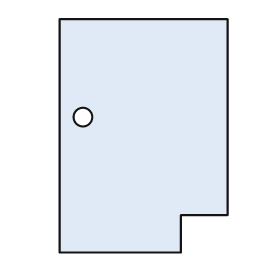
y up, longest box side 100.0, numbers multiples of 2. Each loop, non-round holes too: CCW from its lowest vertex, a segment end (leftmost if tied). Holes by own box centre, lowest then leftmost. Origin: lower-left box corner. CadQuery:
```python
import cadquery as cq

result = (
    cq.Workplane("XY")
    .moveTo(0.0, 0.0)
    .lineTo(52.0, 0.0)
    .lineTo(52.0, 16.0)
    .lineTo(72.0, 16.0)
    .lineTo(72.0, 100.0)
    .lineTo(0.0, 100.0)
    .close()
    .moveTo(10.0, 58.0)
    .circle(4.0)
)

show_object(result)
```